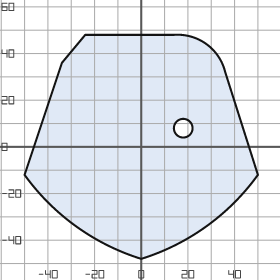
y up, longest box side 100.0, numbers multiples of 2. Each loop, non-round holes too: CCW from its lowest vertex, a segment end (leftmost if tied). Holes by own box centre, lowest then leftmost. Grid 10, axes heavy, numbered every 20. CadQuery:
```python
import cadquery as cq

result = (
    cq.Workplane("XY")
    .moveTo(0.0, -48.0)
    .threePointArc((28.0, -34.0), (50.0, -12.0))
    .lineTo(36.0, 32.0)
    .threePointArc((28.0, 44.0), (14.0, 48.0))
    .lineTo(-24.0, 48.0)
    .lineTo(-34.0, 36.0)
    .lineTo(-50.0, -12.0)
    .threePointArc((-28.0, -34.0), (0.0, -48.0))
    .close()
    .moveTo(18.0, 8.0)
    .circle(4.0)
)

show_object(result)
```